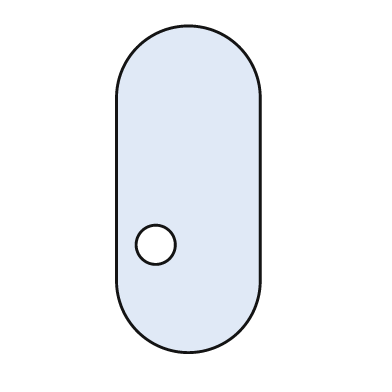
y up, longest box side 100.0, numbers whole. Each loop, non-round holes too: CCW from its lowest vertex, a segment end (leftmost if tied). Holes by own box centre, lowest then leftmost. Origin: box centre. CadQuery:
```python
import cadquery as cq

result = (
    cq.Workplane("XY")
    .moveTo(-22.0, -28.0)
    .threePointArc((0.0, -50.0), (22.0, -28.0))
    .lineTo(22.0, 28.0)
    .threePointArc((0.0, 50.0), (-22.0, 28.0))
    .close()
    .moveTo(-10.0, -17.0)
    .circle(6.0)
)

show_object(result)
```